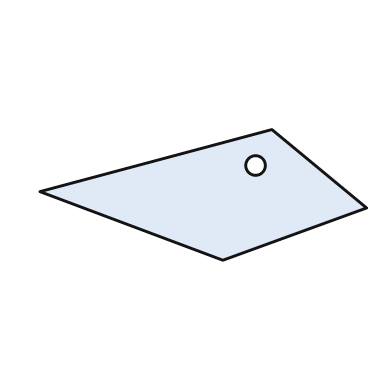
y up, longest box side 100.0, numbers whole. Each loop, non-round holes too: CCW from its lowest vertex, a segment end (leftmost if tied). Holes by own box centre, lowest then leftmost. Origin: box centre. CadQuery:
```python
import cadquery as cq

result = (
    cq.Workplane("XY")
    .moveTo(6.0, -20.0)
    .lineTo(50.0, -4.0)
    .lineTo(21.0, 20.0)
    .lineTo(-50.0, 1.0)
    .close()
    .moveTo(16.0, 9.0)
    .circle(3.0)
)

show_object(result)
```